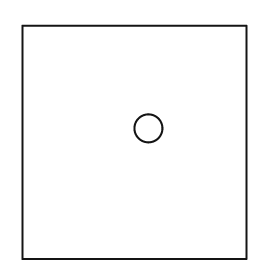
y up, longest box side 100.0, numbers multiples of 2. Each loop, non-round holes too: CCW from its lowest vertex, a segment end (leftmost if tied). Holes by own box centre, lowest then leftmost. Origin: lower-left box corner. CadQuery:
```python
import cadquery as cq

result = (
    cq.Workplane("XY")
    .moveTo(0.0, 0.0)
    .lineTo(96.0, 0.0)
    .lineTo(96.0, 100.0)
    .lineTo(0.0, 100.0)
    .close()
    .moveTo(54.0, 56.0)
    .circle(6.0)
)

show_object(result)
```